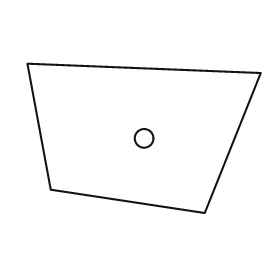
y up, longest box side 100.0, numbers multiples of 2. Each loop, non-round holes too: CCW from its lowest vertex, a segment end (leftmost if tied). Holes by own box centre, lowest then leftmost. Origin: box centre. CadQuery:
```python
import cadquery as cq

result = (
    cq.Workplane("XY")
    .moveTo(26.0, -32.0)
    .lineTo(50.0, 28.0)
    .lineTo(-50.0, 32.0)
    .lineTo(-40.0, -22.0)
    .close()
    .moveTo(0.0, 0.0)
    .circle(4.0)
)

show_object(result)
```